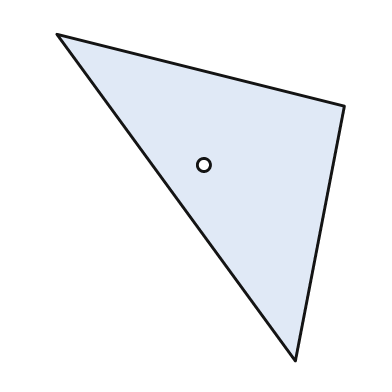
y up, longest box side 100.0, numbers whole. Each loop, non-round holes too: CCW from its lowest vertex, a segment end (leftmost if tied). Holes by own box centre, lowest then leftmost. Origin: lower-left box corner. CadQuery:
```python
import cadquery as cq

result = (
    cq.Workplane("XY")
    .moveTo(73.0, 0.0)
    .lineTo(88.0, 78.0)
    .lineTo(0.0, 100.0)
    .close()
    .moveTo(45.0, 60.0)
    .circle(2.0)
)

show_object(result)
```